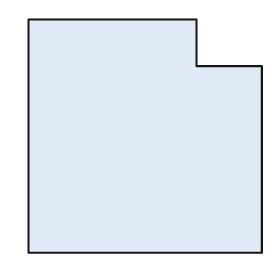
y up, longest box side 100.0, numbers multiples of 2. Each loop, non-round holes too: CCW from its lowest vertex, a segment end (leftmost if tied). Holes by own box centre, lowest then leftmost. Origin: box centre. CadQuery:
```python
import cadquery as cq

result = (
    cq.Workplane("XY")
    .moveTo(-50.0, -50.0)
    .lineTo(50.0, -50.0)
    .lineTo(50.0, 30.0)
    .lineTo(22.0, 30.0)
    .lineTo(22.0, 50.0)
    .lineTo(-50.0, 50.0)
    .close()
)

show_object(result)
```